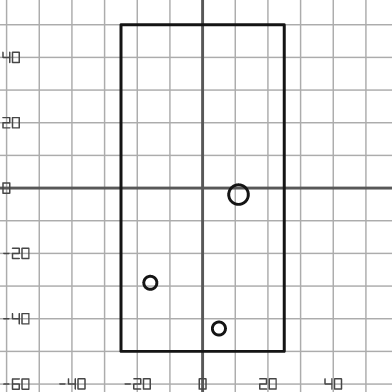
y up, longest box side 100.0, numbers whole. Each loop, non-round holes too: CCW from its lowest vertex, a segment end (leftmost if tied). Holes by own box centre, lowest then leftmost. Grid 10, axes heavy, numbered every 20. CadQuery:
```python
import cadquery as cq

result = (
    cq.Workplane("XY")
    .moveTo(-25.0, -50.0)
    .lineTo(25.0, -50.0)
    .lineTo(25.0, 50.0)
    .lineTo(-25.0, 50.0)
    .close()
    .moveTo(5.0, -43.0)
    .circle(2.0)
    .moveTo(-16.0, -29.0)
    .circle(2.0)
    .moveTo(11.0, -2.0)
    .circle(3.0)
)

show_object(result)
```